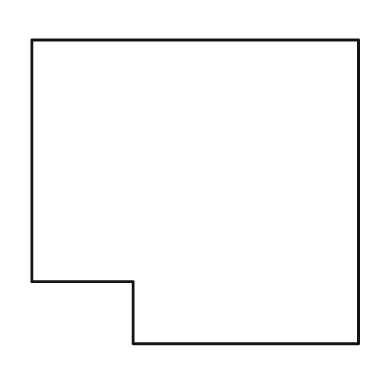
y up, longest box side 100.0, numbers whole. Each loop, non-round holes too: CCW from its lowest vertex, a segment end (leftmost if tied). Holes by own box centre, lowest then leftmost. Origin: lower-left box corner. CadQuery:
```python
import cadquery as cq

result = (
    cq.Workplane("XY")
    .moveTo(31.0, 0.0)
    .lineTo(100.0, 0.0)
    .lineTo(100.0, 93.0)
    .lineTo(0.0, 93.0)
    .lineTo(0.0, 19.0)
    .lineTo(31.0, 19.0)
    .close()
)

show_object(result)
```